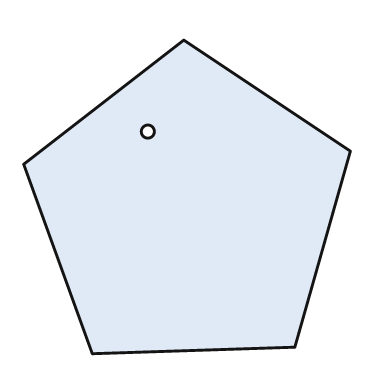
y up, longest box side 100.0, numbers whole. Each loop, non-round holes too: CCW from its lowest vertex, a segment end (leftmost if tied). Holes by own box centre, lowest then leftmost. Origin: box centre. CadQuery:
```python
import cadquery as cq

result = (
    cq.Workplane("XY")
    .moveTo(-29.0, -48.0)
    .lineTo(33.0, -46.0)
    .lineTo(50.0, 14.0)
    .lineTo(-1.0, 48.0)
    .lineTo(-50.0, 10.0)
    .close()
    .moveTo(-12.0, 20.0)
    .circle(2.0)
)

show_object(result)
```